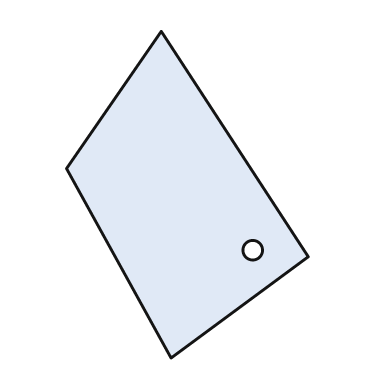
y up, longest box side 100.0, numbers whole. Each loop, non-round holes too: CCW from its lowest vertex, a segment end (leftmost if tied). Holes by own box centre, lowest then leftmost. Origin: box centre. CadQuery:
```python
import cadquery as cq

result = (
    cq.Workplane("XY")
    .moveTo(-5.0, -50.0)
    .lineTo(37.0, -19.0)
    .lineTo(-8.0, 50.0)
    .lineTo(-37.0, 8.0)
    .close()
    .moveTo(20.0, -17.0)
    .circle(3.0)
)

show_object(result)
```